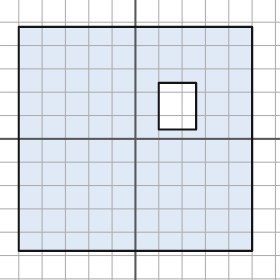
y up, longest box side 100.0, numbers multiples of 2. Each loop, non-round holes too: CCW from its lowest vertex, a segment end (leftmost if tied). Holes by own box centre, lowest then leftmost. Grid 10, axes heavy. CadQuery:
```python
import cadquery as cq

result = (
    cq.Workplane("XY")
    .moveTo(-50.0, -48.0)
    .lineTo(50.0, -48.0)
    .lineTo(50.0, 48.0)
    .lineTo(-50.0, 48.0)
    .close()
    .moveTo(10.0, 4.0)
    .lineTo(26.0, 4.0)
    .lineTo(26.0, 24.0)
    .lineTo(10.0, 24.0)
    .close()
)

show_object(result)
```